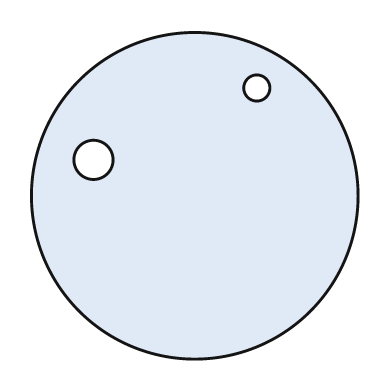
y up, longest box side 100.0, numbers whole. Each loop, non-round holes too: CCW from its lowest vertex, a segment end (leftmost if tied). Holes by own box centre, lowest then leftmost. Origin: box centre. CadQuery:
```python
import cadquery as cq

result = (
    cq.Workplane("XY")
    .moveTo(0.0, 0.0)
    .circle(50.0)
    .moveTo(-31.0, 11.0)
    .circle(6.0)
    .moveTo(19.0, 33.0)
    .circle(4.0)
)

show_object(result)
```